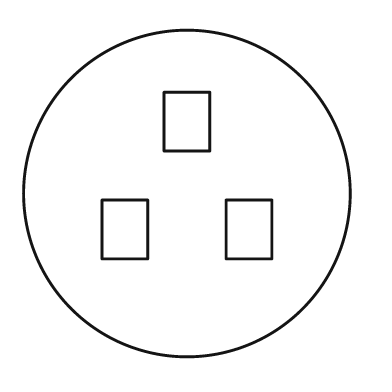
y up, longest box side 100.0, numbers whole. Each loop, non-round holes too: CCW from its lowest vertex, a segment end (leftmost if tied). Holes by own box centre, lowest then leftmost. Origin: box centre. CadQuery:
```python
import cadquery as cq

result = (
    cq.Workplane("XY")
    .moveTo(0.0, 0.0)
    .circle(50.0)
    .moveTo(-26.0, -20.0)
    .lineTo(-12.0, -20.0)
    .lineTo(-12.0, -2.0)
    .lineTo(-26.0, -2.0)
    .close()
    .moveTo(12.0, -20.0)
    .lineTo(26.0, -20.0)
    .lineTo(26.0, -2.0)
    .lineTo(12.0, -2.0)
    .close()
    .moveTo(-7.0, 13.0)
    .lineTo(7.0, 13.0)
    .lineTo(7.0, 31.0)
    .lineTo(-7.0, 31.0)
    .close()
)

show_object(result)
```